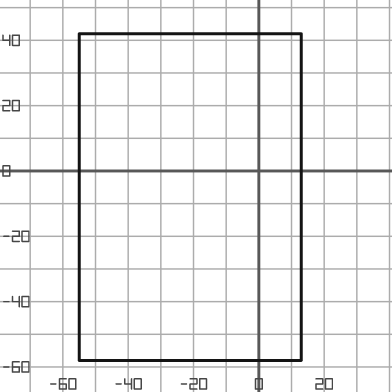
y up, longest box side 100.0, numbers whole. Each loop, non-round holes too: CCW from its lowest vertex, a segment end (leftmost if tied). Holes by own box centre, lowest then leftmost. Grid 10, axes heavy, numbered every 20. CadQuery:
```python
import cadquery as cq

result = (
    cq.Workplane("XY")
    .moveTo(-55.0, -58.0)
    .lineTo(13.0, -58.0)
    .lineTo(13.0, 42.0)
    .lineTo(-55.0, 42.0)
    .close()
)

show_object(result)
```